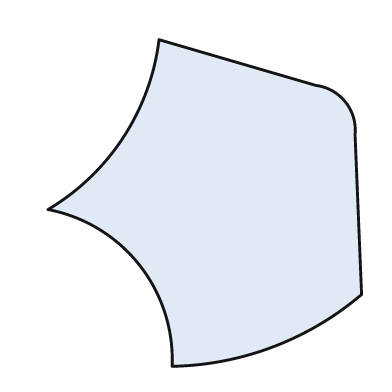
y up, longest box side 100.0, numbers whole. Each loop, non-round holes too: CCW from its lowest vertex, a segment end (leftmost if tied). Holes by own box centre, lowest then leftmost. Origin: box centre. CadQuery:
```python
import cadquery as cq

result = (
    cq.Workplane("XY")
    .moveTo(-10.0, -50.0)
    .threePointArc((21.0, -44.0), (48.0, -28.0))
    .lineTo(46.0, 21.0)
    .threePointArc((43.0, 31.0), (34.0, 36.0))
    .lineTo(-14.0, 50.0)
    .threePointArc((-25.0, 20.0), (-48.0, -2.0))
    .threePointArc((-20.0, -19.0), (-10.0, -50.0))
    .close()
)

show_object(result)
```